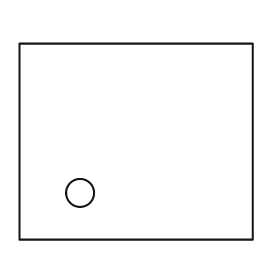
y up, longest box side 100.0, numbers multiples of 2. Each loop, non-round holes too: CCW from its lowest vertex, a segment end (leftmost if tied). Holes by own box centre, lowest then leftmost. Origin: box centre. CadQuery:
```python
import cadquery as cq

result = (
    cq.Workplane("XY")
    .moveTo(-50.0, -42.0)
    .lineTo(50.0, -42.0)
    .lineTo(50.0, 42.0)
    .lineTo(-50.0, 42.0)
    .close()
    .moveTo(-24.0, -22.0)
    .circle(6.0)
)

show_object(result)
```